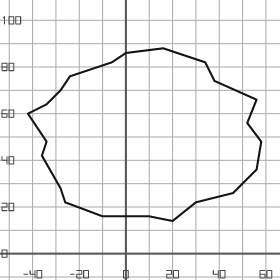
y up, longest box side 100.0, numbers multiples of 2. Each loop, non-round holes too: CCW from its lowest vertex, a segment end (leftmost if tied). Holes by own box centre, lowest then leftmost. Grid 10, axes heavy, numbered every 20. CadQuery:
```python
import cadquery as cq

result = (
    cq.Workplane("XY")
    .moveTo(20.0, 14.0)
    .lineTo(30.0, 22.0)
    .lineTo(46.0, 26.0)
    .lineTo(56.0, 36.0)
    .lineTo(58.0, 48.0)
    .lineTo(52.0, 56.0)
    .lineTo(56.0, 66.0)
    .lineTo(38.0, 74.0)
    .lineTo(34.0, 82.0)
    .lineTo(16.0, 88.0)
    .lineTo(0.0, 86.0)
    .lineTo(-6.0, 82.0)
    .lineTo(-24.0, 76.0)
    .lineTo(-28.0, 70.0)
    .lineTo(-34.0, 64.0)
    .lineTo(-42.0, 60.0)
    .lineTo(-34.0, 48.0)
    .lineTo(-36.0, 42.0)
    .lineTo(-28.0, 28.0)
    .lineTo(-26.0, 22.0)
    .lineTo(-10.0, 16.0)
    .lineTo(10.0, 16.0)
    .close()
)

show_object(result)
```